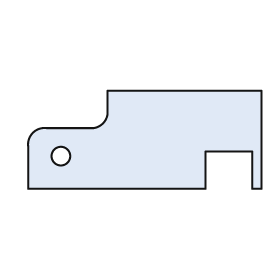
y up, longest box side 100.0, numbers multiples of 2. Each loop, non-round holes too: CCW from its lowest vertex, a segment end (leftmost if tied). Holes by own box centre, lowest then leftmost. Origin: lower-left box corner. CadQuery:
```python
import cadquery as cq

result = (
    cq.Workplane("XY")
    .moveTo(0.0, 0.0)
    .lineTo(76.0, 0.0)
    .lineTo(76.0, 16.0)
    .lineTo(96.0, 16.0)
    .lineTo(96.0, 0.0)
    .lineTo(100.0, 0.0)
    .lineTo(100.0, 42.0)
    .lineTo(34.0, 42.0)
    .lineTo(34.0, 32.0)
    .threePointArc((32.0, 28.0), (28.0, 26.0))
    .lineTo(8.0, 26.0)
    .threePointArc((2.0, 24.0), (0.0, 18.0))
    .close()
    .moveTo(14.0, 14.0)
    .circle(4.0)
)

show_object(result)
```